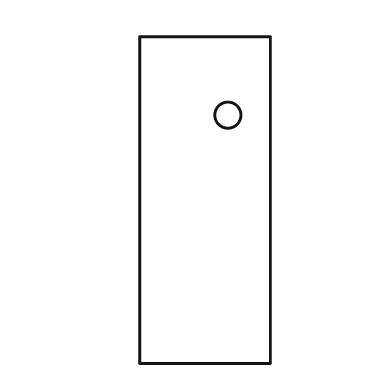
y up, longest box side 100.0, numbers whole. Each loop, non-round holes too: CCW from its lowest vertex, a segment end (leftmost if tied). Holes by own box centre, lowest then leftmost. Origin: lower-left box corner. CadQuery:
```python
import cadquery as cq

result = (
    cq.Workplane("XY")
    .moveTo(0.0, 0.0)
    .lineTo(40.0, 0.0)
    .lineTo(40.0, 100.0)
    .lineTo(0.0, 100.0)
    .close()
    .moveTo(27.0, 76.0)
    .circle(4.0)
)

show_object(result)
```